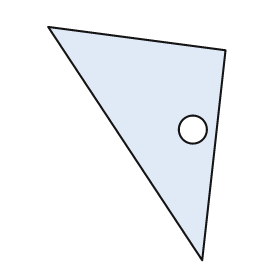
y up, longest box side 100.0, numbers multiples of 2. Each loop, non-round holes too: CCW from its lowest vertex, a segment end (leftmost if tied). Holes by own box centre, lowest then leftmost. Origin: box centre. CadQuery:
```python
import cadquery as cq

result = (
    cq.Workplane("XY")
    .moveTo(28.0, -50.0)
    .lineTo(38.0, 40.0)
    .lineTo(-38.0, 50.0)
    .close()
    .moveTo(24.0, 6.0)
    .circle(6.0)
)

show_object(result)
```